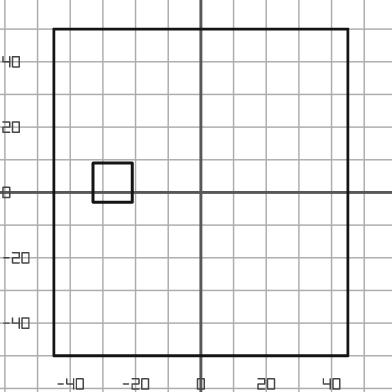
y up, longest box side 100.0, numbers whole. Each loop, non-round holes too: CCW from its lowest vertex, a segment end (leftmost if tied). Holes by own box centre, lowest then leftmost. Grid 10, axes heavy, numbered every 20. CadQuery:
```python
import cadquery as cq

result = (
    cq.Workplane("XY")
    .moveTo(-45.0, -50.0)
    .lineTo(45.0, -50.0)
    .lineTo(45.0, 50.0)
    .lineTo(-45.0, 50.0)
    .close()
    .moveTo(-33.0, -3.0)
    .lineTo(-21.0, -3.0)
    .lineTo(-21.0, 9.0)
    .lineTo(-33.0, 9.0)
    .close()
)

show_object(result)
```